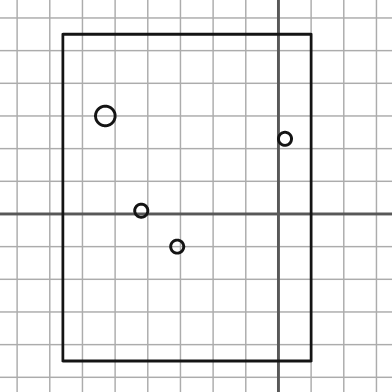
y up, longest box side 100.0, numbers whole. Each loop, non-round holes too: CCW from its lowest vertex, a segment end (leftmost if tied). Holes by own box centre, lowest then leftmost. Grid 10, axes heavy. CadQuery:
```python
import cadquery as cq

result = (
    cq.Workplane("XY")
    .moveTo(-66.0, -45.0)
    .lineTo(10.0, -45.0)
    .lineTo(10.0, 55.0)
    .lineTo(-66.0, 55.0)
    .close()
    .moveTo(-31.0, -10.0)
    .circle(2.0)
    .moveTo(-42.0, 1.0)
    .circle(2.0)
    .moveTo(2.0, 23.0)
    .circle(2.0)
    .moveTo(-53.0, 30.0)
    .circle(3.0)
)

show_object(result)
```